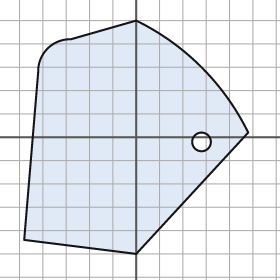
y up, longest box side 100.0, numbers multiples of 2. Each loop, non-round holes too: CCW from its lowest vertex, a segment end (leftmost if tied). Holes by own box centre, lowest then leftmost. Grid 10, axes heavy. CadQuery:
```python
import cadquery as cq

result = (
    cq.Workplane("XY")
    .moveTo(0.0, -50.0)
    .lineTo(48.0, 2.0)
    .threePointArc((28.0, 30.0), (0.0, 50.0))
    .lineTo(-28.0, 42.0)
    .threePointArc((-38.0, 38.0), (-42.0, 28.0))
    .lineTo(-48.0, -44.0)
    .close()
    .moveTo(28.0, -2.0)
    .circle(4.0)
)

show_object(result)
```